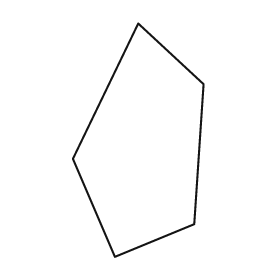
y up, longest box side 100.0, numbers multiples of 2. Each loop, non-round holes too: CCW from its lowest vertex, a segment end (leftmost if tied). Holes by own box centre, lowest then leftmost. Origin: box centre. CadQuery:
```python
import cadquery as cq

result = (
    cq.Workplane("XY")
    .moveTo(-10.0, -50.0)
    .lineTo(24.0, -36.0)
    .lineTo(28.0, 24.0)
    .lineTo(0.0, 50.0)
    .lineTo(-28.0, -8.0)
    .close()
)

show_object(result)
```